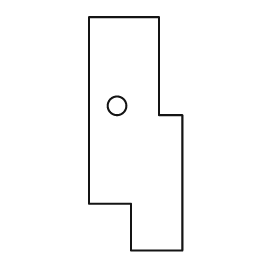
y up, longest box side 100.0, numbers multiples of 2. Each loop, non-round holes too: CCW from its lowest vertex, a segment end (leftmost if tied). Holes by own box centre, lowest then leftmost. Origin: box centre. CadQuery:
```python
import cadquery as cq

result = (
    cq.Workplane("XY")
    .moveTo(-2.0, -50.0)
    .lineTo(20.0, -50.0)
    .lineTo(20.0, 8.0)
    .lineTo(10.0, 8.0)
    .lineTo(10.0, 50.0)
    .lineTo(-20.0, 50.0)
    .lineTo(-20.0, -30.0)
    .lineTo(-2.0, -30.0)
    .close()
    .moveTo(-8.0, 12.0)
    .circle(4.0)
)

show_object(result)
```